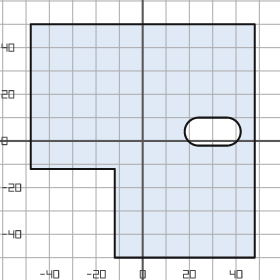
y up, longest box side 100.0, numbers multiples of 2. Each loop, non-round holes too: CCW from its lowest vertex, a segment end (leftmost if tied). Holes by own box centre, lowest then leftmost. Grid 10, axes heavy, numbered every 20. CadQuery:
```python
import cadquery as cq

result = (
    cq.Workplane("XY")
    .moveTo(-12.0, -50.0)
    .lineTo(48.0, -50.0)
    .lineTo(48.0, 50.0)
    .lineTo(-48.0, 50.0)
    .lineTo(-48.0, -12.0)
    .lineTo(-12.0, -12.0)
    .close()
    .moveTo(24.0, -2.0)
    .lineTo(36.0, -2.0)
    .threePointArc((42.0, 4.0), (36.0, 10.0))
    .lineTo(24.0, 10.0)
    .threePointArc((18.0, 4.0), (24.0, -2.0))
    .close()
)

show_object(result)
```